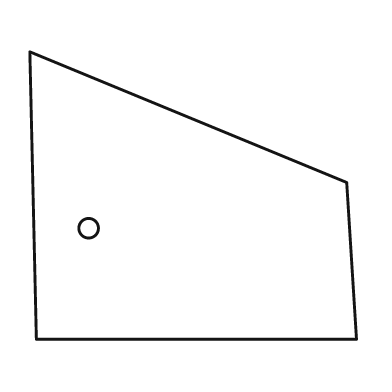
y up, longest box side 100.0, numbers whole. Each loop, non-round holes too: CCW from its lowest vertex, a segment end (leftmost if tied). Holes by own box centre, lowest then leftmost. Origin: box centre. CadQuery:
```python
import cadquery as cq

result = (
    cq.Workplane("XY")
    .moveTo(-48.0, -44.0)
    .lineTo(50.0, -44.0)
    .lineTo(47.0, 4.0)
    .lineTo(-50.0, 44.0)
    .close()
    .moveTo(-32.0, -10.0)
    .circle(3.0)
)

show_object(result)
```